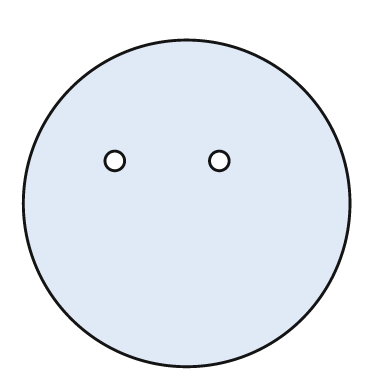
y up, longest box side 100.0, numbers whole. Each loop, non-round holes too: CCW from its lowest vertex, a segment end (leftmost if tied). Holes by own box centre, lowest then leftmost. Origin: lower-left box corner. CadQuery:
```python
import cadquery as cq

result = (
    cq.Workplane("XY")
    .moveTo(50.0, 50.0)
    .circle(50.0)
    .moveTo(28.0, 63.0)
    .circle(3.0)
    .moveTo(60.0, 63.0)
    .circle(3.0)
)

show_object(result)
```